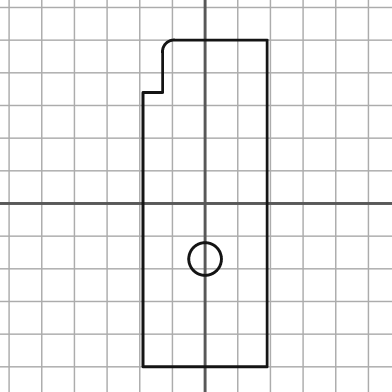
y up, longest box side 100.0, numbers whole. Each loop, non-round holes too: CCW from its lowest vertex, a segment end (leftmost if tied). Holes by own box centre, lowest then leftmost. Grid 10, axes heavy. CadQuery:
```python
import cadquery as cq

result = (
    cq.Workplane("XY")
    .moveTo(-19.0, -50.0)
    .lineTo(19.0, -50.0)
    .lineTo(19.0, 50.0)
    .lineTo(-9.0, 50.0)
    .threePointArc((-12.0, 49.0), (-13.0, 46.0))
    .lineTo(-13.0, 34.0)
    .lineTo(-19.0, 34.0)
    .close()
    .moveTo(0.0, -17.0)
    .circle(5.0)
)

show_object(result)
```